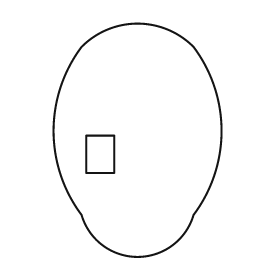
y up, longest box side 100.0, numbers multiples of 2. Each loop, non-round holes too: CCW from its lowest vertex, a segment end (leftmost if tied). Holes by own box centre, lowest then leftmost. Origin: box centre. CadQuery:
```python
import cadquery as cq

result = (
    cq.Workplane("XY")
    .moveTo(-24.0, -32.0)
    .threePointArc((0.0, -50.0), (24.0, -32.0))
    .threePointArc((36.0, 4.0), (24.0, 40.0))
    .threePointArc((0.0, 50.0), (-24.0, 40.0))
    .threePointArc((-36.0, 4.0), (-24.0, -32.0))
    .close()
    .moveTo(-22.0, -14.0)
    .lineTo(-10.0, -14.0)
    .lineTo(-10.0, 2.0)
    .lineTo(-22.0, 2.0)
    .close()
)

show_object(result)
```